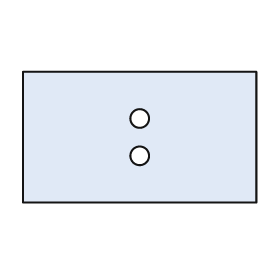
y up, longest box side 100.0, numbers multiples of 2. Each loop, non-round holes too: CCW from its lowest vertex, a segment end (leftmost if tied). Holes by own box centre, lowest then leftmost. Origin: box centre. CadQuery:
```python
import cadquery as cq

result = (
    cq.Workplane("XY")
    .moveTo(-50.0, -28.0)
    .lineTo(50.0, -28.0)
    .lineTo(50.0, 28.0)
    .lineTo(-50.0, 28.0)
    .close()
    .moveTo(0.0, -8.0)
    .circle(4.0)
    .moveTo(0.0, 8.0)
    .circle(4.0)
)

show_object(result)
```